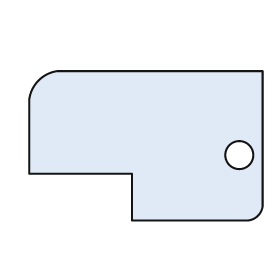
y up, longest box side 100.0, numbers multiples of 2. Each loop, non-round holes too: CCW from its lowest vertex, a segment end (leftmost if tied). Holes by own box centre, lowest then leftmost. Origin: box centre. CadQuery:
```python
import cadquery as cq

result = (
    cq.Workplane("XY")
    .moveTo(-6.0, -32.0)
    .lineTo(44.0, -32.0)
    .threePointArc((48.0, -30.0), (50.0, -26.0))
    .lineTo(50.0, 32.0)
    .lineTo(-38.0, 32.0)
    .threePointArc((-46.0, 28.0), (-50.0, 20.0))
    .lineTo(-50.0, -12.0)
    .lineTo(-6.0, -12.0)
    .close()
    .moveTo(40.0, -4.0)
    .circle(6.0)
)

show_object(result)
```